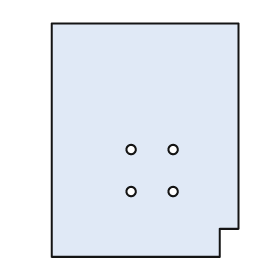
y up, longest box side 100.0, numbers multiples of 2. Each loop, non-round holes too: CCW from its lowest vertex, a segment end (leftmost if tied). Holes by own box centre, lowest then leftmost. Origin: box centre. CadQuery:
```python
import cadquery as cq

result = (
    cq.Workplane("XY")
    .moveTo(-40.0, -50.0)
    .lineTo(32.0, -50.0)
    .lineTo(32.0, -38.0)
    .lineTo(40.0, -38.0)
    .lineTo(40.0, 50.0)
    .lineTo(-40.0, 50.0)
    .close()
    .moveTo(-6.0, -22.0)
    .circle(2.0)
    .moveTo(12.0, -22.0)
    .circle(2.0)
    .moveTo(-6.0, -4.0)
    .circle(2.0)
    .moveTo(12.0, -4.0)
    .circle(2.0)
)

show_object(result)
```